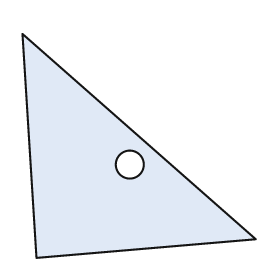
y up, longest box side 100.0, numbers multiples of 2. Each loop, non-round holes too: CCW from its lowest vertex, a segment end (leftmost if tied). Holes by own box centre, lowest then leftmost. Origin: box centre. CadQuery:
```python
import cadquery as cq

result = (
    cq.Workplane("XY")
    .moveTo(-44.0, -48.0)
    .lineTo(50.0, -40.0)
    .lineTo(-50.0, 48.0)
    .close()
    .moveTo(-4.0, -8.0)
    .circle(6.0)
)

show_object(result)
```